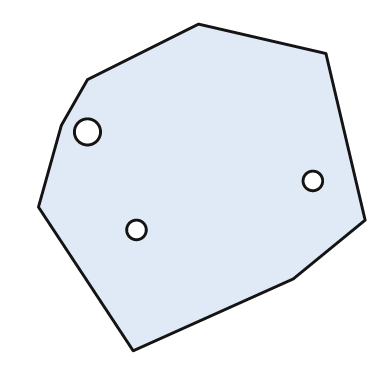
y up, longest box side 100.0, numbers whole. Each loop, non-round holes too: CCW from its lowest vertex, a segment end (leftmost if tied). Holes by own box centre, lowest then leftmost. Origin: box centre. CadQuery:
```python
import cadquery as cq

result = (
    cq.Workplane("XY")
    .moveTo(-21.0, -50.0)
    .lineTo(28.0, -28.0)
    .lineTo(50.0, -10.0)
    .lineTo(38.0, 41.0)
    .lineTo(-1.0, 50.0)
    .lineTo(-35.0, 33.0)
    .lineTo(-43.0, 19.0)
    .lineTo(-50.0, -6.0)
    .close()
    .moveTo(-20.0, -13.0)
    .circle(3.0)
    .moveTo(34.0, 2.0)
    .circle(3.0)
    .moveTo(-35.0, 17.0)
    .circle(4.0)
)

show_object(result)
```